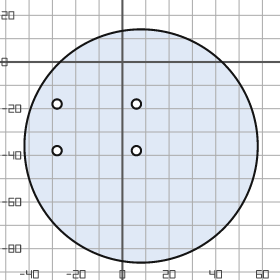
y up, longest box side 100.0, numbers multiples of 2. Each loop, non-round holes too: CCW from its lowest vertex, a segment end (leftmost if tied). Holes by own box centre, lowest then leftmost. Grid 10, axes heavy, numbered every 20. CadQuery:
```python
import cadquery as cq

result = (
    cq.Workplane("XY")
    .moveTo(8.0, -36.0)
    .circle(50.0)
    .moveTo(-28.0, -38.0)
    .circle(2.0)
    .moveTo(6.0, -38.0)
    .circle(2.0)
    .moveTo(-28.0, -18.0)
    .circle(2.0)
    .moveTo(6.0, -18.0)
    .circle(2.0)
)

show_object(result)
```